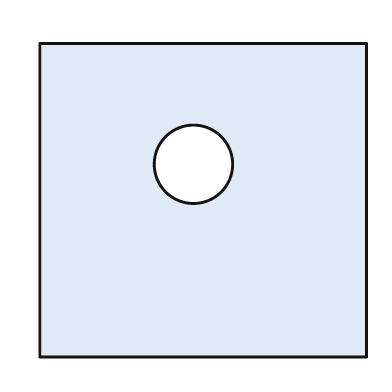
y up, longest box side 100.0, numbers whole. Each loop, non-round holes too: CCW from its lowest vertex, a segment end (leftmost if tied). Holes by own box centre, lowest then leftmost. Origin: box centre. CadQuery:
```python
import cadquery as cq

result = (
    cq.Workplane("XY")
    .moveTo(-50.0, -48.0)
    .lineTo(50.0, -48.0)
    .lineTo(50.0, 48.0)
    .lineTo(-50.0, 48.0)
    .close()
    .moveTo(-3.0, 11.0)
    .circle(12.0)
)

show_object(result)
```